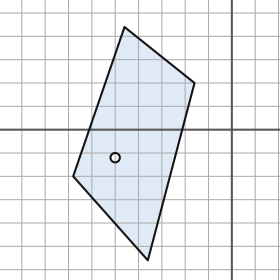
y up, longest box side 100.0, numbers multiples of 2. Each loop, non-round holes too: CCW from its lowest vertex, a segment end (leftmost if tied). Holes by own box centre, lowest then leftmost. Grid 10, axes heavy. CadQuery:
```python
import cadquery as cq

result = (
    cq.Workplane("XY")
    .moveTo(-36.0, -56.0)
    .lineTo(-16.0, 20.0)
    .lineTo(-46.0, 44.0)
    .lineTo(-68.0, -20.0)
    .close()
    .moveTo(-50.0, -12.0)
    .circle(2.0)
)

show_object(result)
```